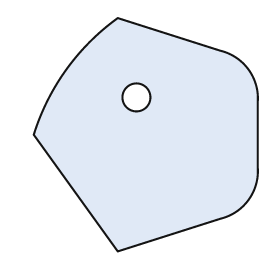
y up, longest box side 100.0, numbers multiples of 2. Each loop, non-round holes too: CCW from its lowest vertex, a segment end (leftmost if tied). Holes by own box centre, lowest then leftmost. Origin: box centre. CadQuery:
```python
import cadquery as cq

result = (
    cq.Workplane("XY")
    .moveTo(-12.0, -50.0)
    .lineTo(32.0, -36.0)
    .threePointArc((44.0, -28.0), (48.0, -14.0))
    .lineTo(48.0, 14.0)
    .threePointArc((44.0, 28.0), (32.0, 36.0))
    .lineTo(-12.0, 50.0)
    .threePointArc((-34.0, 28.0), (-48.0, 0.0))
    .close()
    .moveTo(-4.0, 16.0)
    .circle(6.0)
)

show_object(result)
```